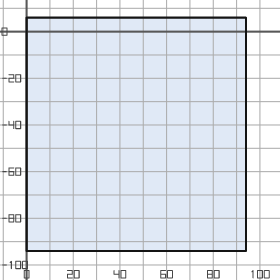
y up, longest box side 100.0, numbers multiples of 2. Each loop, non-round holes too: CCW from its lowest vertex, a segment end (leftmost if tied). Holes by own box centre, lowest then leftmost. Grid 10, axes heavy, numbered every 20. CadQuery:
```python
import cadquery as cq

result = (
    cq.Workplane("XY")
    .moveTo(0.0, -94.0)
    .lineTo(94.0, -94.0)
    .lineTo(94.0, 6.0)
    .lineTo(0.0, 6.0)
    .close()
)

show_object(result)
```